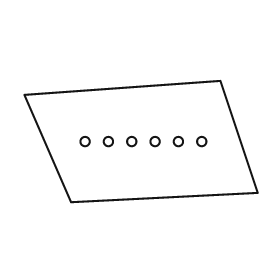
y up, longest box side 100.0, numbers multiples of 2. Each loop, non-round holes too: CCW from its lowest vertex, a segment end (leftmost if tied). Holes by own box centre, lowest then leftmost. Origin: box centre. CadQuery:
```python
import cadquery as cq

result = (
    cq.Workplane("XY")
    .moveTo(-30.0, -26.0)
    .lineTo(50.0, -22.0)
    .lineTo(34.0, 26.0)
    .lineTo(-50.0, 20.0)
    .close()
    .moveTo(-24.0, 0.0)
    .circle(2.0)
    .moveTo(-14.0, 0.0)
    .circle(2.0)
    .moveTo(-4.0, 0.0)
    .circle(2.0)
    .moveTo(6.0, 0.0)
    .circle(2.0)
    .moveTo(16.0, 0.0)
    .circle(2.0)
    .moveTo(26.0, 0.0)
    .circle(2.0)
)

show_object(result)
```